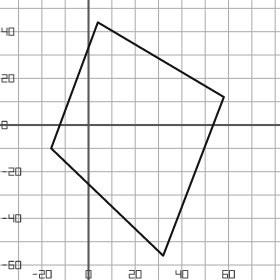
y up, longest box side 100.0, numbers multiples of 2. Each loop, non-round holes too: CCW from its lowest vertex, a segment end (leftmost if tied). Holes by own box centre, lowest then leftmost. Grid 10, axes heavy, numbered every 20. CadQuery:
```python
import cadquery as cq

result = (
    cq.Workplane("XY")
    .moveTo(32.0, -56.0)
    .lineTo(58.0, 12.0)
    .lineTo(4.0, 44.0)
    .lineTo(-16.0, -10.0)
    .close()
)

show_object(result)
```